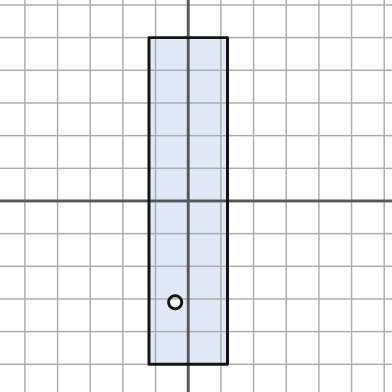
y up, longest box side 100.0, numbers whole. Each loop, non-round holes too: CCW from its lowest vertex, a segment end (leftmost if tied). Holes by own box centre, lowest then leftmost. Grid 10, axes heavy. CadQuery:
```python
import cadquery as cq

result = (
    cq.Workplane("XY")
    .moveTo(-12.0, -50.0)
    .lineTo(12.0, -50.0)
    .lineTo(12.0, 50.0)
    .lineTo(-12.0, 50.0)
    .close()
    .moveTo(-4.0, -31.0)
    .circle(2.0)
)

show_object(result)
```